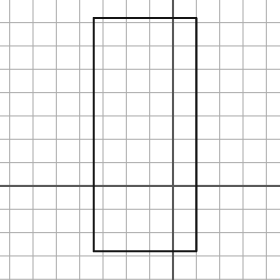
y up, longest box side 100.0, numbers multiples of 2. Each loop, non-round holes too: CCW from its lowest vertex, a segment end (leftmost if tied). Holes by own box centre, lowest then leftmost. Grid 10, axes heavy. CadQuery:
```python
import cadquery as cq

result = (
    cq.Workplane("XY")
    .moveTo(-34.0, -28.0)
    .lineTo(10.0, -28.0)
    .lineTo(10.0, 72.0)
    .lineTo(-34.0, 72.0)
    .close()
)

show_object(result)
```